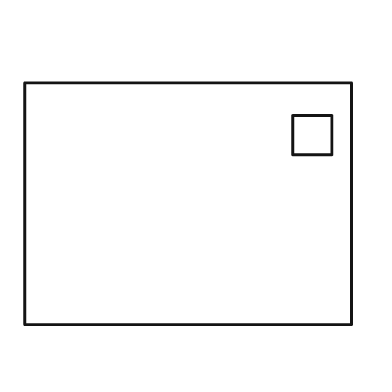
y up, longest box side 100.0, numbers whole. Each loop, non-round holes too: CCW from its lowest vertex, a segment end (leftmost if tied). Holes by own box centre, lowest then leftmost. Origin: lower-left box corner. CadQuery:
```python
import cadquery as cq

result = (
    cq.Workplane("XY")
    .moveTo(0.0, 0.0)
    .lineTo(100.0, 0.0)
    .lineTo(100.0, 74.0)
    .lineTo(0.0, 74.0)
    .close()
    .moveTo(82.0, 52.0)
    .lineTo(94.0, 52.0)
    .lineTo(94.0, 64.0)
    .lineTo(82.0, 64.0)
    .close()
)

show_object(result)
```